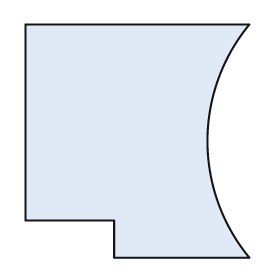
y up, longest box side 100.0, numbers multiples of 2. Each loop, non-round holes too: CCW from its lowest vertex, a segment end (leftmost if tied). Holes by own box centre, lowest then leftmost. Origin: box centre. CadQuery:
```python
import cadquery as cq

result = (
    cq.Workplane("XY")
    .moveTo(-10.0, -50.0)
    .lineTo(48.0, -50.0)
    .threePointArc((30.0, 0.0), (48.0, 50.0))
    .lineTo(-48.0, 50.0)
    .lineTo(-48.0, -34.0)
    .lineTo(-10.0, -34.0)
    .close()
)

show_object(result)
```